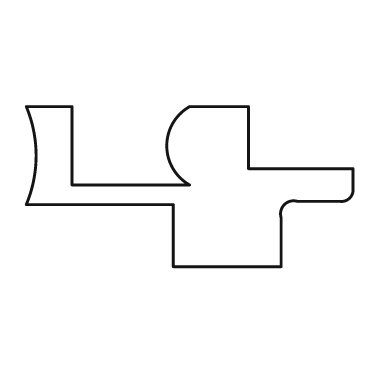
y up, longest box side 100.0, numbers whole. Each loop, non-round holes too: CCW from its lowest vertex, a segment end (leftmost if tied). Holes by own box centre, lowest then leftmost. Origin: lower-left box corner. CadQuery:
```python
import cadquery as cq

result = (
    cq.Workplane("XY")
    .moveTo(45.0, 0.0)
    .lineTo(78.0, 0.0)
    .lineTo(78.0, 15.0)
    .threePointArc((79.0, 19.0), (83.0, 20.0))
    .lineTo(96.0, 20.0)
    .threePointArc((99.0, 21.0), (100.0, 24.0))
    .lineTo(100.0, 30.0)
    .lineTo(68.0, 30.0)
    .lineTo(68.0, 49.0)
    .lineTo(50.0, 49.0)
    .threePointArc((43.0, 37.0), (50.0, 25.0))
    .lineTo(14.0, 25.0)
    .lineTo(14.0, 49.0)
    .lineTo(0.0, 49.0)
    .threePointArc((3.0, 34.0), (0.0, 19.0))
    .lineTo(45.0, 19.0)
    .close()
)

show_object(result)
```